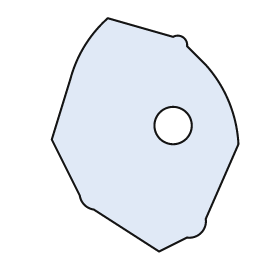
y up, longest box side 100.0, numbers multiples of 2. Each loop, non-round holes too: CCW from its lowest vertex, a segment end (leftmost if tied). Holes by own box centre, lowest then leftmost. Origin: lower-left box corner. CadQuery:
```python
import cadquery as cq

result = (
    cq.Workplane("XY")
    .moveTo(46.0, 0.0)
    .lineTo(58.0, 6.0)
    .threePointArc((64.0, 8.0), (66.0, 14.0))
    .lineTo(80.0, 46.0)
    .threePointArc((76.0, 64.0), (66.0, 80.0))
    .lineTo(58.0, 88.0)
    .threePointArc((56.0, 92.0), (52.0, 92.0))
    .lineTo(24.0, 100.0)
    .threePointArc((14.0, 88.0), (8.0, 74.0))
    .lineTo(0.0, 48.0)
    .lineTo(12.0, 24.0)
    .threePointArc((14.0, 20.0), (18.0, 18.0))
    .close()
    .moveTo(52.0, 54.0)
    .circle(8.0)
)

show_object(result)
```